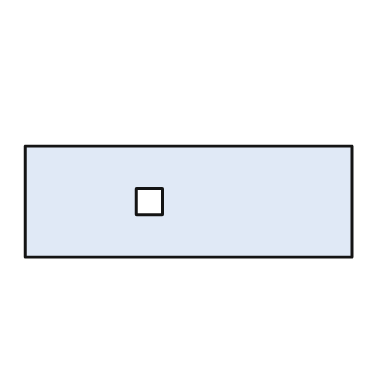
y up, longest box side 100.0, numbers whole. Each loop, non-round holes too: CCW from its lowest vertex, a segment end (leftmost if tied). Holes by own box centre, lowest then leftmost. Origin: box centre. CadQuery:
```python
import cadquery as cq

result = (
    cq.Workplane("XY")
    .moveTo(-50.0, -17.0)
    .lineTo(50.0, -17.0)
    .lineTo(50.0, 17.0)
    .lineTo(-50.0, 17.0)
    .close()
    .moveTo(-16.0, -4.0)
    .lineTo(-8.0, -4.0)
    .lineTo(-8.0, 4.0)
    .lineTo(-16.0, 4.0)
    .close()
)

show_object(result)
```